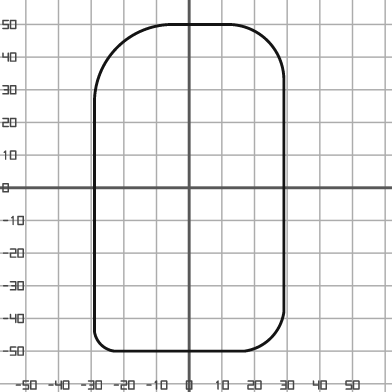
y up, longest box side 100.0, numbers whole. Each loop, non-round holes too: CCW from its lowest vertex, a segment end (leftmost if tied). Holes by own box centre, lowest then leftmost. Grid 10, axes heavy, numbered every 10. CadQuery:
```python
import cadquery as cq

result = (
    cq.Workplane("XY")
    .moveTo(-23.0, -50.0)
    .lineTo(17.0, -50.0)
    .threePointArc((25.0, -46.0), (29.0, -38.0))
    .lineTo(29.0, 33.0)
    .threePointArc((24.0, 45.0), (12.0, 50.0))
    .lineTo(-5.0, 50.0)
    .threePointArc((-22.0, 43.0), (-29.0, 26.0))
    .lineTo(-29.0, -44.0)
    .threePointArc((-27.0, -48.0), (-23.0, -50.0))
    .close()
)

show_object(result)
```